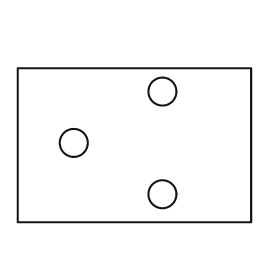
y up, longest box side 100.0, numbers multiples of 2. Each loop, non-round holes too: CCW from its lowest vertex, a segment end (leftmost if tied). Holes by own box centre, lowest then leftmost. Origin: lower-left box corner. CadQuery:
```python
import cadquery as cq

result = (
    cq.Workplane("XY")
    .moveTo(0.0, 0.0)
    .lineTo(100.0, 0.0)
    .lineTo(100.0, 66.0)
    .lineTo(0.0, 66.0)
    .close()
    .moveTo(62.0, 12.0)
    .circle(6.0)
    .moveTo(24.0, 34.0)
    .circle(6.0)
    .moveTo(62.0, 56.0)
    .circle(6.0)
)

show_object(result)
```